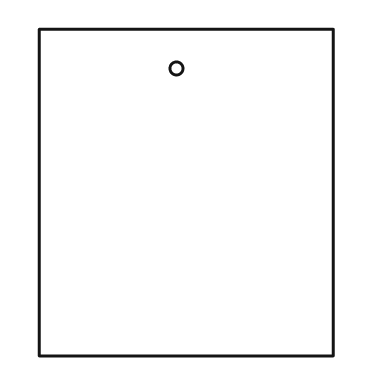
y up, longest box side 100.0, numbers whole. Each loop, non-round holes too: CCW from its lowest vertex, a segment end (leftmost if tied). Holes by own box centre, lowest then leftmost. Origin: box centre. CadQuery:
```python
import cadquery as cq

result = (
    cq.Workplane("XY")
    .moveTo(-45.0, -50.0)
    .lineTo(45.0, -50.0)
    .lineTo(45.0, 50.0)
    .lineTo(-45.0, 50.0)
    .close()
    .moveTo(-3.0, 38.0)
    .circle(2.0)
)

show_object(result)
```